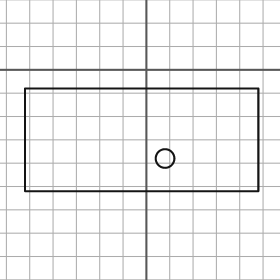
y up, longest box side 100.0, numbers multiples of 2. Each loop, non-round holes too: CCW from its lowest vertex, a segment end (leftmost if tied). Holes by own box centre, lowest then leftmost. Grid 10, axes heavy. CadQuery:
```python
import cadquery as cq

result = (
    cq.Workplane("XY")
    .moveTo(-52.0, -52.0)
    .lineTo(48.0, -52.0)
    .lineTo(48.0, -8.0)
    .lineTo(-52.0, -8.0)
    .close()
    .moveTo(8.0, -38.0)
    .circle(4.0)
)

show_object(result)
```